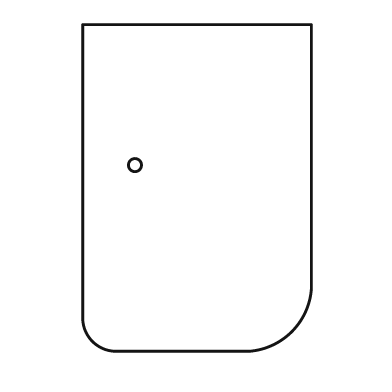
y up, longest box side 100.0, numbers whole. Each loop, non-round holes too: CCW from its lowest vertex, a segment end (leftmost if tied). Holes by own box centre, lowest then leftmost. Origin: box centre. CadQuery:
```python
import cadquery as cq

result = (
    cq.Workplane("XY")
    .moveTo(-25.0, -50.0)
    .lineTo(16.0, -50.0)
    .threePointArc((29.0, -44.0), (35.0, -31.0))
    .lineTo(35.0, 50.0)
    .lineTo(-35.0, 50.0)
    .lineTo(-35.0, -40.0)
    .threePointArc((-32.0, -47.0), (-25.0, -50.0))
    .close()
    .moveTo(-19.0, 7.0)
    .circle(2.0)
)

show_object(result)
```